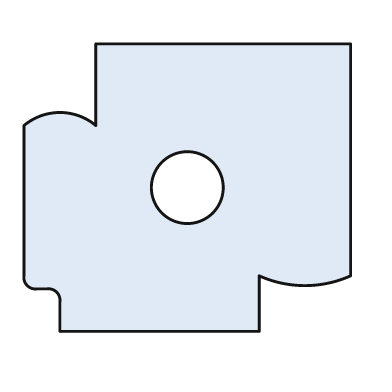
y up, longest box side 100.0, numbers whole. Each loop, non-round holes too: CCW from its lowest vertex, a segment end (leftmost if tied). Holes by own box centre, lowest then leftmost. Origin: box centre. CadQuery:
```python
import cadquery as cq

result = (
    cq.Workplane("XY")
    .moveTo(-39.0, -44.0)
    .lineTo(22.0, -44.0)
    .lineTo(22.0, -27.0)
    .threePointArc((36.0, -30.0), (50.0, -27.0))
    .lineTo(50.0, 44.0)
    .lineTo(-28.0, 44.0)
    .lineTo(-28.0, 19.0)
    .threePointArc((-39.0, 23.0), (-50.0, 19.0))
    .lineTo(-50.0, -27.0)
    .threePointArc((-49.0, -30.0), (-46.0, -31.0))
    .lineTo(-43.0, -31.0)
    .threePointArc((-40.0, -32.0), (-39.0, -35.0))
    .close()
    .moveTo(0.0, 0.0)
    .circle(11.0)
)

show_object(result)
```